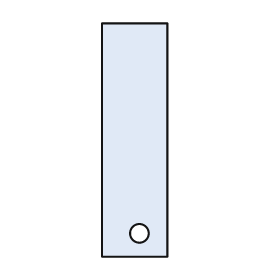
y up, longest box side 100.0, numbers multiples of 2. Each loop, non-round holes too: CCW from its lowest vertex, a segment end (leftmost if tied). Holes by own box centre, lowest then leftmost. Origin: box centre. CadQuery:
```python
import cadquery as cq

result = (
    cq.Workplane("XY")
    .moveTo(-14.0, -50.0)
    .lineTo(14.0, -50.0)
    .lineTo(14.0, 50.0)
    .lineTo(-14.0, 50.0)
    .close()
    .moveTo(2.0, -40.0)
    .circle(4.0)
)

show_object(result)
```